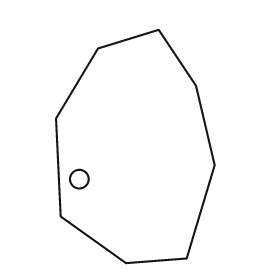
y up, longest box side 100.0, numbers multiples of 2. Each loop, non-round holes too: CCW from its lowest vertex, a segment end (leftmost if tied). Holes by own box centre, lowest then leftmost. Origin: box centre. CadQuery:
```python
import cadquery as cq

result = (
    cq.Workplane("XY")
    .moveTo(-4.0, -50.0)
    .lineTo(22.0, -48.0)
    .lineTo(34.0, -8.0)
    .lineTo(26.0, 26.0)
    .lineTo(10.0, 50.0)
    .lineTo(-16.0, 42.0)
    .lineTo(-34.0, 12.0)
    .lineTo(-32.0, -30.0)
    .close()
    .moveTo(-24.0, -14.0)
    .circle(4.0)
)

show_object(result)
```